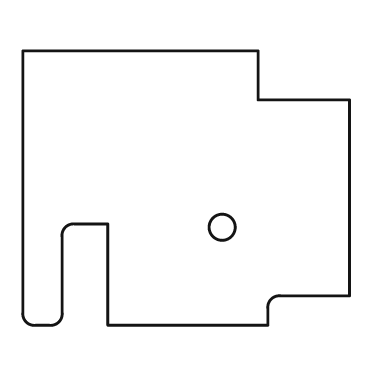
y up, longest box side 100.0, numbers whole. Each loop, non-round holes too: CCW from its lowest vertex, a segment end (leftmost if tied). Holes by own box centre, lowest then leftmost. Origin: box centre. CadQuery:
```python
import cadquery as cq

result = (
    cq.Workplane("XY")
    .moveTo(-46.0, -42.0)
    .lineTo(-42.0, -42.0)
    .threePointArc((-39.0, -41.0), (-38.0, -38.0))
    .lineTo(-38.0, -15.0)
    .threePointArc((-37.0, -12.0), (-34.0, -11.0))
    .lineTo(-24.0, -11.0)
    .lineTo(-24.0, -42.0)
    .lineTo(25.0, -42.0)
    .lineTo(25.0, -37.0)
    .threePointArc((26.0, -34.0), (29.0, -33.0))
    .lineTo(50.0, -33.0)
    .lineTo(50.0, 27.0)
    .lineTo(22.0, 27.0)
    .lineTo(22.0, 42.0)
    .lineTo(-50.0, 42.0)
    .lineTo(-50.0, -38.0)
    .threePointArc((-49.0, -41.0), (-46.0, -42.0))
    .close()
    .moveTo(11.0, -12.0)
    .circle(4.0)
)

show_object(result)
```